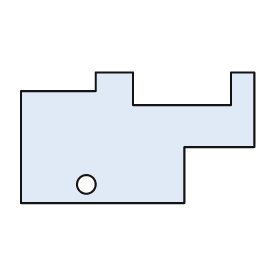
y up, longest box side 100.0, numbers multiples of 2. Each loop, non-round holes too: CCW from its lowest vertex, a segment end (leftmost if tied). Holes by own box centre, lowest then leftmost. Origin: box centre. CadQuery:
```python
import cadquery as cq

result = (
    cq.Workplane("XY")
    .moveTo(-50.0, -28.0)
    .lineTo(20.0, -28.0)
    .lineTo(20.0, -4.0)
    .lineTo(50.0, -4.0)
    .lineTo(50.0, 28.0)
    .lineTo(40.0, 28.0)
    .lineTo(40.0, 14.0)
    .lineTo(-2.0, 14.0)
    .lineTo(-2.0, 28.0)
    .lineTo(-18.0, 28.0)
    .lineTo(-18.0, 20.0)
    .lineTo(-50.0, 20.0)
    .close()
    .moveTo(-22.0, -20.0)
    .circle(4.0)
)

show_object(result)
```